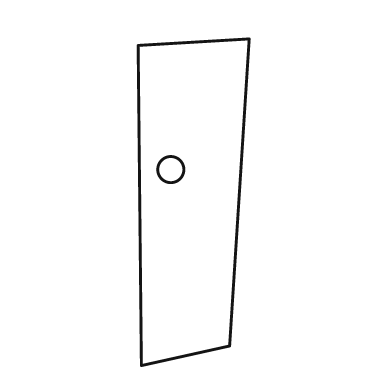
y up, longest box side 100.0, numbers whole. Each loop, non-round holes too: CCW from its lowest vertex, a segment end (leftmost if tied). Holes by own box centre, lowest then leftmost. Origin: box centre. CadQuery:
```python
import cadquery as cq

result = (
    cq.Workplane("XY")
    .moveTo(-16.0, -50.0)
    .lineTo(11.0, -44.0)
    .lineTo(17.0, 50.0)
    .lineTo(-17.0, 48.0)
    .close()
    .moveTo(-7.0, 10.0)
    .circle(4.0)
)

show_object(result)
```